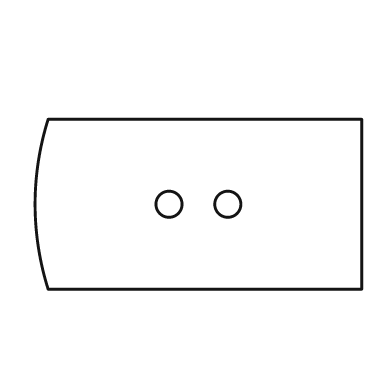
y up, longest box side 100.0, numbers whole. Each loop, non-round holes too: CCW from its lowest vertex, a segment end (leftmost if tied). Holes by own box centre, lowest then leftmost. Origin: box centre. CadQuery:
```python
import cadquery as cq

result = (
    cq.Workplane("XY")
    .moveTo(-46.0, -26.0)
    .lineTo(50.0, -26.0)
    .lineTo(50.0, 26.0)
    .lineTo(-46.0, 26.0)
    .threePointArc((-50.0, 0.0), (-46.0, -26.0))
    .close()
    .moveTo(-9.0, 0.0)
    .circle(4.0)
    .moveTo(9.0, 0.0)
    .circle(4.0)
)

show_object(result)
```